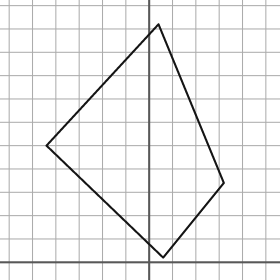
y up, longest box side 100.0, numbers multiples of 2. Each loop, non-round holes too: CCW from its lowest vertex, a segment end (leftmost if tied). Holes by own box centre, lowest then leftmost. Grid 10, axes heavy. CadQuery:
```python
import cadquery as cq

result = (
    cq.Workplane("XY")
    .moveTo(6.0, 2.0)
    .lineTo(32.0, 34.0)
    .lineTo(4.0, 102.0)
    .lineTo(-44.0, 50.0)
    .close()
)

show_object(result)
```